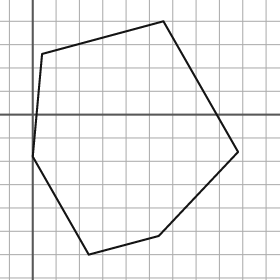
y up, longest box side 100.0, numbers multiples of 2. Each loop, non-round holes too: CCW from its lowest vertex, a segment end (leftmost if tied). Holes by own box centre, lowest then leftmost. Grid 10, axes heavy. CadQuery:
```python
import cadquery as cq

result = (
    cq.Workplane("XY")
    .moveTo(24.0, -60.0)
    .lineTo(54.0, -52.0)
    .lineTo(88.0, -16.0)
    .lineTo(56.0, 40.0)
    .lineTo(4.0, 26.0)
    .lineTo(0.0, -18.0)
    .close()
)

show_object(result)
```